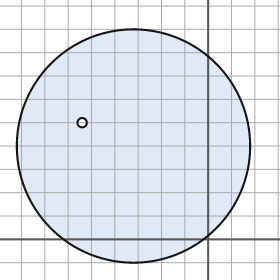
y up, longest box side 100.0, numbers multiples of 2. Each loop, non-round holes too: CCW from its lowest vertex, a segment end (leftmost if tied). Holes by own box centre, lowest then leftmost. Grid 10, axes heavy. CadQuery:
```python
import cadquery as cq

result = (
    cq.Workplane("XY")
    .moveTo(-32.0, 40.0)
    .circle(50.0)
    .moveTo(-54.0, 50.0)
    .circle(2.0)
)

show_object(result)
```